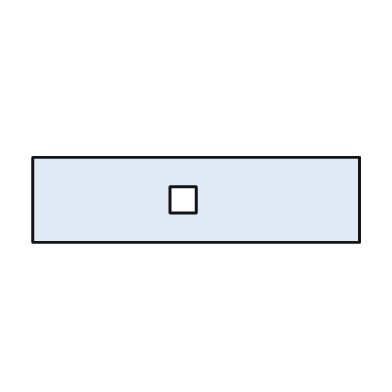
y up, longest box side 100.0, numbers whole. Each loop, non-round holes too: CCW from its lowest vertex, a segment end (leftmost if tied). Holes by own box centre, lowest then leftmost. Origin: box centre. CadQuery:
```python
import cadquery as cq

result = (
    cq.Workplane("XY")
    .moveTo(-50.0, -13.0)
    .lineTo(50.0, -13.0)
    .lineTo(50.0, 13.0)
    .lineTo(-50.0, 13.0)
    .close()
    .moveTo(-8.0, -4.0)
    .lineTo(0.0, -4.0)
    .lineTo(0.0, 4.0)
    .lineTo(-8.0, 4.0)
    .close()
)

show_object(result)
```